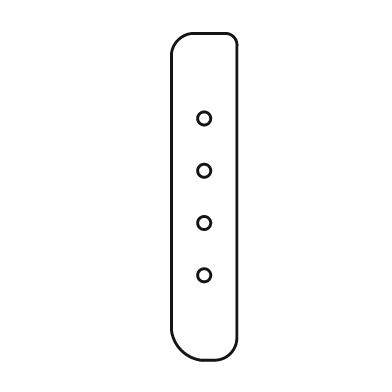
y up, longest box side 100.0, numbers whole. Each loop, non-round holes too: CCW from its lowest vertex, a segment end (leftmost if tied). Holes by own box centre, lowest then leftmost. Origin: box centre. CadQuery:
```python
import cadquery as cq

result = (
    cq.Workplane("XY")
    .moveTo(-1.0, -50.0)
    .lineTo(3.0, -50.0)
    .threePointArc((8.0, -48.0), (10.0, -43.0))
    .lineTo(10.0, 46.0)
    .threePointArc((9.0, 49.0), (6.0, 50.0))
    .lineTo(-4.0, 50.0)
    .threePointArc((-8.0, 48.0), (-10.0, 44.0))
    .lineTo(-10.0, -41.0)
    .threePointArc((-7.0, -47.0), (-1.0, -50.0))
    .close()
    .moveTo(0.0, -24.0)
    .circle(2.0)
    .moveTo(0.0, -8.0)
    .circle(2.0)
    .moveTo(0.0, 8.0)
    .circle(2.0)
    .moveTo(0.0, 24.0)
    .circle(2.0)
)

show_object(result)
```